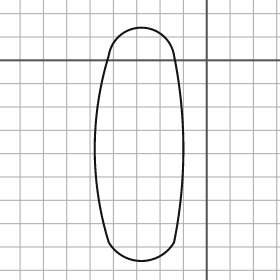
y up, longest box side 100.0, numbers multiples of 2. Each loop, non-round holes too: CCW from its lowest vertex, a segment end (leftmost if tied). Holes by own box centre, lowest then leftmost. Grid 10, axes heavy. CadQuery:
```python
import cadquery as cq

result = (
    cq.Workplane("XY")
    .moveTo(-42.0, -78.0)
    .threePointArc((-28.0, -86.0), (-14.0, -78.0))
    .threePointArc((-10.0, -38.0), (-14.0, 2.0))
    .threePointArc((-28.0, 14.0), (-42.0, 2.0))
    .threePointArc((-48.0, -38.0), (-42.0, -78.0))
    .close()
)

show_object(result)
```